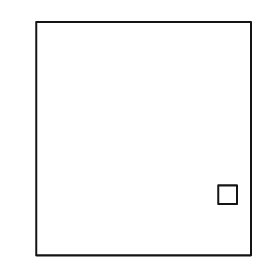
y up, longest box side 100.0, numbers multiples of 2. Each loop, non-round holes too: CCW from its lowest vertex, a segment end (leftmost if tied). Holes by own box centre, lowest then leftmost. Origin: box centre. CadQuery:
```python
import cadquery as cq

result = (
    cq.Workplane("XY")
    .moveTo(-46.0, -50.0)
    .lineTo(46.0, -50.0)
    .lineTo(46.0, 50.0)
    .lineTo(-46.0, 50.0)
    .close()
    .moveTo(32.0, -28.0)
    .lineTo(40.0, -28.0)
    .lineTo(40.0, -20.0)
    .lineTo(32.0, -20.0)
    .close()
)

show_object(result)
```